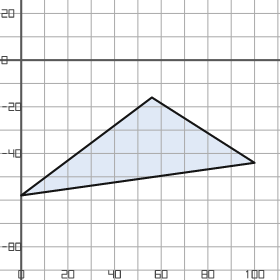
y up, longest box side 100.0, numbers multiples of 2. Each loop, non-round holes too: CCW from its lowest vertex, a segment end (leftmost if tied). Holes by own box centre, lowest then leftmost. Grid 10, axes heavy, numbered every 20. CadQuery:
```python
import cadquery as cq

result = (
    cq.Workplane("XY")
    .moveTo(0.0, -58.0)
    .lineTo(100.0, -44.0)
    .lineTo(56.0, -16.0)
    .close()
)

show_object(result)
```